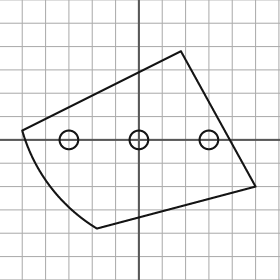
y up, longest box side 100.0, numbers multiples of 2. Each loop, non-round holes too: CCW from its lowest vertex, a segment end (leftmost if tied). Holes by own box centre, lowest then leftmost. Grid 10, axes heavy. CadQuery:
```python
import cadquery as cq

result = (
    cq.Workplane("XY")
    .moveTo(-18.0, -38.0)
    .lineTo(50.0, -20.0)
    .lineTo(18.0, 38.0)
    .lineTo(-50.0, 4.0)
    .threePointArc((-38.0, -20.0), (-18.0, -38.0))
    .close()
    .moveTo(-30.0, 0.0)
    .circle(4.0)
    .moveTo(0.0, 0.0)
    .circle(4.0)
    .moveTo(30.0, 0.0)
    .circle(4.0)
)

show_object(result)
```